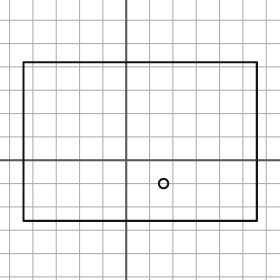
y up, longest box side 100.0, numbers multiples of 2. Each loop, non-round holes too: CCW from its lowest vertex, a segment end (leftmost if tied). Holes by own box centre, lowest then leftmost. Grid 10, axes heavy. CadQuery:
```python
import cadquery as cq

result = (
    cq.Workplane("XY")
    .moveTo(-44.0, -26.0)
    .lineTo(56.0, -26.0)
    .lineTo(56.0, 42.0)
    .lineTo(-44.0, 42.0)
    .close()
    .moveTo(16.0, -10.0)
    .circle(2.0)
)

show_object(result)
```